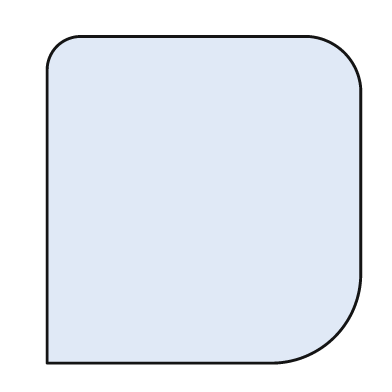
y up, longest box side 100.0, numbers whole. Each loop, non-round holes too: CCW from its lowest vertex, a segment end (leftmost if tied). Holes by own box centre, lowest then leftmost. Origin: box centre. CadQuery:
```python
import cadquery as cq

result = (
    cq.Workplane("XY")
    .moveTo(-48.0, -50.0)
    .lineTo(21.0, -50.0)
    .threePointArc((40.0, -42.0), (48.0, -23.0))
    .lineTo(48.0, 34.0)
    .threePointArc((43.0, 45.0), (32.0, 50.0))
    .lineTo(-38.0, 50.0)
    .threePointArc((-45.0, 47.0), (-48.0, 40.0))
    .close()
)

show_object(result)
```